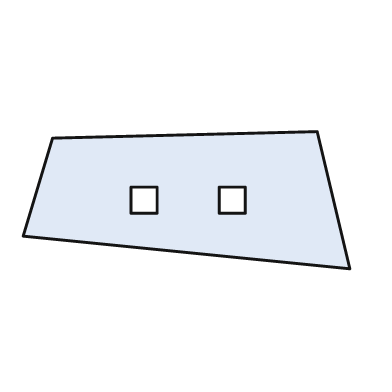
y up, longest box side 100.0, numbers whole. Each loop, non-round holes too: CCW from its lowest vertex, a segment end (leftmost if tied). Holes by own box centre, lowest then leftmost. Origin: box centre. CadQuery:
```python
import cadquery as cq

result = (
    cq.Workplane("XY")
    .moveTo(50.0, -21.0)
    .lineTo(40.0, 21.0)
    .lineTo(-41.0, 19.0)
    .lineTo(-50.0, -11.0)
    .close()
    .moveTo(-17.0, -4.0)
    .lineTo(-9.0, -4.0)
    .lineTo(-9.0, 4.0)
    .lineTo(-17.0, 4.0)
    .close()
    .moveTo(10.0, -4.0)
    .lineTo(18.0, -4.0)
    .lineTo(18.0, 4.0)
    .lineTo(10.0, 4.0)
    .close()
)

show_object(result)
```